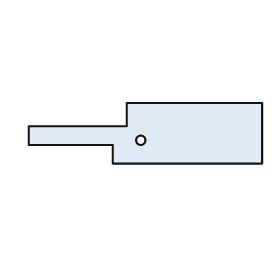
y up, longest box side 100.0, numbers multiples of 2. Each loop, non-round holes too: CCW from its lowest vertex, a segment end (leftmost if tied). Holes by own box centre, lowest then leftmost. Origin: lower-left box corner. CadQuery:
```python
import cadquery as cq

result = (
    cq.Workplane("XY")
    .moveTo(36.0, 0.0)
    .lineTo(100.0, 0.0)
    .lineTo(100.0, 26.0)
    .lineTo(42.0, 26.0)
    .lineTo(42.0, 16.0)
    .lineTo(0.0, 16.0)
    .lineTo(0.0, 8.0)
    .lineTo(36.0, 8.0)
    .close()
    .moveTo(48.0, 10.0)
    .circle(2.0)
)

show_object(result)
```